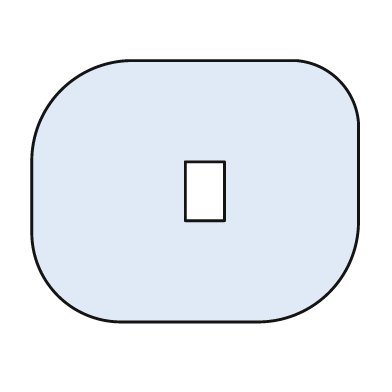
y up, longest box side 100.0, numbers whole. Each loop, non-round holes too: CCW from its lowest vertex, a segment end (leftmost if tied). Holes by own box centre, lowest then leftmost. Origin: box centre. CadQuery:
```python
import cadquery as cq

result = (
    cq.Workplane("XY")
    .moveTo(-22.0, -40.0)
    .lineTo(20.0, -40.0)
    .threePointArc((41.0, -31.0), (50.0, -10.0))
    .lineTo(50.0, 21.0)
    .threePointArc((44.0, 34.0), (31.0, 40.0))
    .lineTo(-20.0, 40.0)
    .threePointArc((-41.0, 31.0), (-50.0, 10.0))
    .lineTo(-50.0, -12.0)
    .threePointArc((-42.0, -32.0), (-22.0, -40.0))
    .close()
    .moveTo(-3.0, -9.0)
    .lineTo(9.0, -9.0)
    .lineTo(9.0, 9.0)
    .lineTo(-3.0, 9.0)
    .close()
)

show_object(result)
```